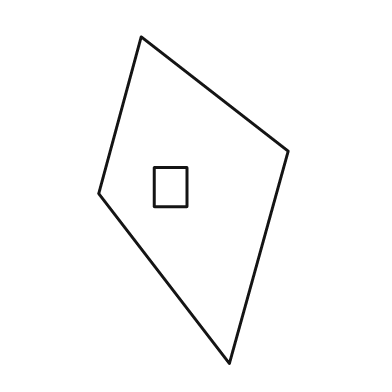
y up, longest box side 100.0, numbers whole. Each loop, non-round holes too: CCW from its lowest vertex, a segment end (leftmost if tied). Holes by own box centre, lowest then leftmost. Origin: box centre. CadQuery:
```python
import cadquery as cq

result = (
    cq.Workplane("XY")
    .moveTo(11.0, -50.0)
    .lineTo(29.0, 15.0)
    .lineTo(-16.0, 50.0)
    .lineTo(-29.0, 2.0)
    .close()
    .moveTo(-12.0, -2.0)
    .lineTo(-2.0, -2.0)
    .lineTo(-2.0, 10.0)
    .lineTo(-12.0, 10.0)
    .close()
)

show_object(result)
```